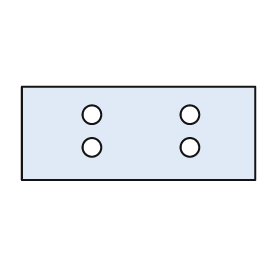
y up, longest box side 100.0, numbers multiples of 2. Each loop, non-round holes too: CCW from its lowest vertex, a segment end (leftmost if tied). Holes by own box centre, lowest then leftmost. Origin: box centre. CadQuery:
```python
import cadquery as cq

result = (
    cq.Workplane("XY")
    .moveTo(-50.0, -20.0)
    .lineTo(50.0, -20.0)
    .lineTo(50.0, 20.0)
    .lineTo(-50.0, 20.0)
    .close()
    .moveTo(-20.0, -6.0)
    .circle(4.0)
    .moveTo(22.0, -6.0)
    .circle(4.0)
    .moveTo(-20.0, 8.0)
    .circle(4.0)
    .moveTo(22.0, 8.0)
    .circle(4.0)
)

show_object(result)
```